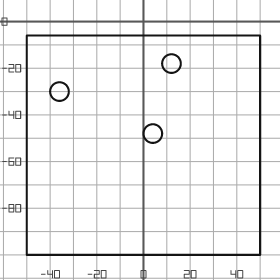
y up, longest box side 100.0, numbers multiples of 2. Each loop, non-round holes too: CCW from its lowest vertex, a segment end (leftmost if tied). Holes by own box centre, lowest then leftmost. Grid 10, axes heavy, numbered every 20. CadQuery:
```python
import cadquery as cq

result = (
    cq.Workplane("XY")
    .moveTo(-50.0, -100.0)
    .lineTo(50.0, -100.0)
    .lineTo(50.0, -6.0)
    .lineTo(-50.0, -6.0)
    .close()
    .moveTo(4.0, -48.0)
    .circle(4.0)
    .moveTo(-36.0, -30.0)
    .circle(4.0)
    .moveTo(12.0, -18.0)
    .circle(4.0)
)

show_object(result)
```